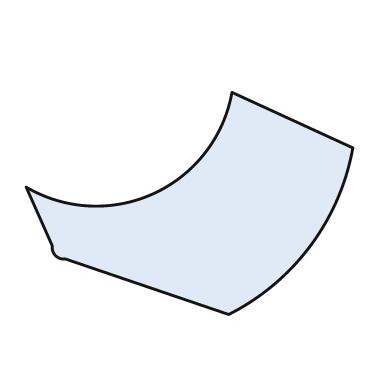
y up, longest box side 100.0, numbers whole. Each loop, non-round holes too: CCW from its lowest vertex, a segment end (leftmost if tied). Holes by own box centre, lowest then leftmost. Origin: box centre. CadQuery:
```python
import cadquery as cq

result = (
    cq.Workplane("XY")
    .moveTo(12.0, -34.0)
    .threePointArc((37.0, -13.0), (50.0, 17.0))
    .lineTo(13.0, 34.0)
    .threePointArc((-11.0, 3.0), (-50.0, 5.0))
    .lineTo(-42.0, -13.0)
    .threePointArc((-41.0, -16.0), (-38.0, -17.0))
    .close()
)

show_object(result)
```